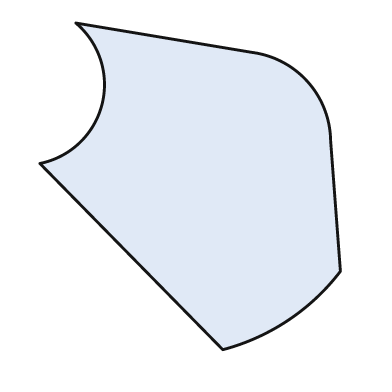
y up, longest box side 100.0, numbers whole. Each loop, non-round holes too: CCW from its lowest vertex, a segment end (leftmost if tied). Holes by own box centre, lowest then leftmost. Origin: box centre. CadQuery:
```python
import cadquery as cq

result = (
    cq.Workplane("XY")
    .moveTo(10.0, -50.0)
    .threePointArc((30.0, -41.0), (46.0, -26.0))
    .lineTo(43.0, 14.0)
    .threePointArc((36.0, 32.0), (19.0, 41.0))
    .lineTo(-35.0, 50.0)
    .threePointArc((-27.0, 25.0), (-46.0, 7.0))
    .close()
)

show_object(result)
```